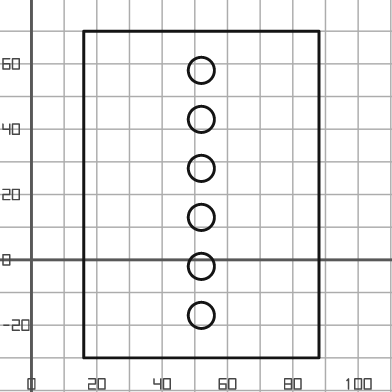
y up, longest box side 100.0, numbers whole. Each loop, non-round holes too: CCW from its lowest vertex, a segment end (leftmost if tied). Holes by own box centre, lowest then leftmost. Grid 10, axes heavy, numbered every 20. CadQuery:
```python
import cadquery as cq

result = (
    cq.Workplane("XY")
    .moveTo(16.0, -30.0)
    .lineTo(88.0, -30.0)
    .lineTo(88.0, 70.0)
    .lineTo(16.0, 70.0)
    .close()
    .moveTo(52.0, -17.0)
    .circle(4.0)
    .moveTo(52.0, -2.0)
    .circle(4.0)
    .moveTo(52.0, 13.0)
    .circle(4.0)
    .moveTo(52.0, 28.0)
    .circle(4.0)
    .moveTo(52.0, 43.0)
    .circle(4.0)
    .moveTo(52.0, 58.0)
    .circle(4.0)
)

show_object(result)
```